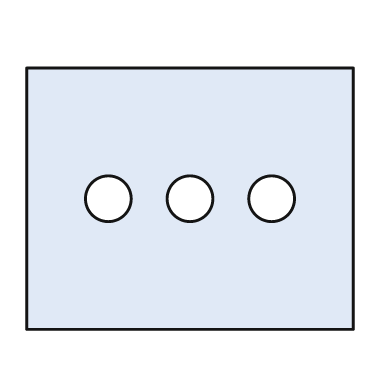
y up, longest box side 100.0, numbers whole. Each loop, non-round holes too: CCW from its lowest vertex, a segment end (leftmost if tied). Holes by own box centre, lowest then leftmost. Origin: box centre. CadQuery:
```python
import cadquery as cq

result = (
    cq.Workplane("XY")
    .moveTo(-50.0, -40.0)
    .lineTo(50.0, -40.0)
    .lineTo(50.0, 40.0)
    .lineTo(-50.0, 40.0)
    .close()
    .moveTo(-25.0, 0.0)
    .circle(7.0)
    .moveTo(0.0, 0.0)
    .circle(7.0)
    .moveTo(25.0, 0.0)
    .circle(7.0)
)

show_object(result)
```